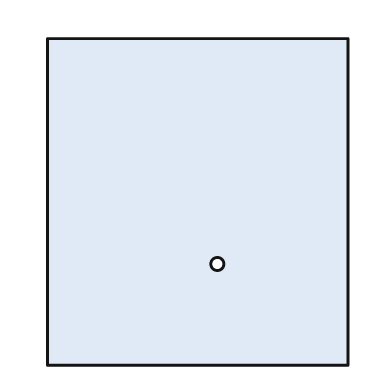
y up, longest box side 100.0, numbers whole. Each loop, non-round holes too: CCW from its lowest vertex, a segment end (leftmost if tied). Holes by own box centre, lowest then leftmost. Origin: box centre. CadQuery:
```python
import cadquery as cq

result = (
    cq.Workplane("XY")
    .moveTo(-46.0, -50.0)
    .lineTo(46.0, -50.0)
    .lineTo(46.0, 50.0)
    .lineTo(-46.0, 50.0)
    .close()
    .moveTo(6.0, -19.0)
    .circle(2.0)
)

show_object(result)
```